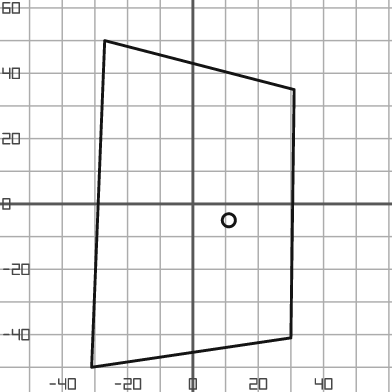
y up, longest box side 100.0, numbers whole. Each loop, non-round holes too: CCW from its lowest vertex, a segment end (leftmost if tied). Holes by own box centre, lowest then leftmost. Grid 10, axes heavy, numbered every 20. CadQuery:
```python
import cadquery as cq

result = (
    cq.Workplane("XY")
    .moveTo(-31.0, -50.0)
    .lineTo(30.0, -41.0)
    .lineTo(31.0, 35.0)
    .lineTo(-27.0, 50.0)
    .close()
    .moveTo(11.0, -5.0)
    .circle(2.0)
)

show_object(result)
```